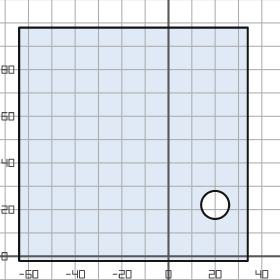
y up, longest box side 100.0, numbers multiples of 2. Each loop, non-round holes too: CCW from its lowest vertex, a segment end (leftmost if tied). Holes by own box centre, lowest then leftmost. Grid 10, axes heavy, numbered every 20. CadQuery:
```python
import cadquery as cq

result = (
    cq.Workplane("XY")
    .moveTo(-64.0, -2.0)
    .lineTo(34.0, -2.0)
    .lineTo(34.0, 98.0)
    .lineTo(-64.0, 98.0)
    .close()
    .moveTo(20.0, 22.0)
    .circle(6.0)
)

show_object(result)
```